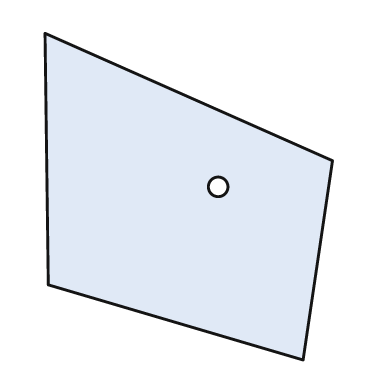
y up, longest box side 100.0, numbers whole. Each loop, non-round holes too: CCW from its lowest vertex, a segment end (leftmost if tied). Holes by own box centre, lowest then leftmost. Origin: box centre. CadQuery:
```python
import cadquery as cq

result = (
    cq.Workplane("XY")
    .moveTo(35.0, -50.0)
    .lineTo(44.0, 11.0)
    .lineTo(-44.0, 50.0)
    .lineTo(-43.0, -27.0)
    .close()
    .moveTo(9.0, 3.0)
    .circle(3.0)
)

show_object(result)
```